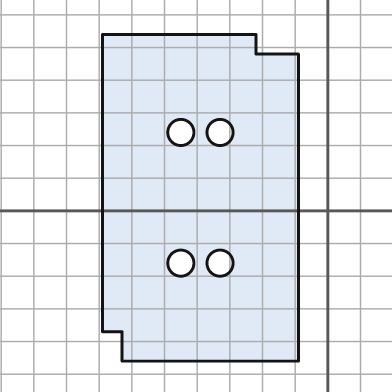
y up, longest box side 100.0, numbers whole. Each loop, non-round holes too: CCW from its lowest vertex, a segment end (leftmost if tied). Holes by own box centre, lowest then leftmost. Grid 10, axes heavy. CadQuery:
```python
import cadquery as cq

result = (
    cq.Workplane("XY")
    .moveTo(-63.0, -46.0)
    .lineTo(-9.0, -46.0)
    .lineTo(-9.0, 48.0)
    .lineTo(-22.0, 48.0)
    .lineTo(-22.0, 54.0)
    .lineTo(-69.0, 54.0)
    .lineTo(-69.0, -37.0)
    .lineTo(-63.0, -37.0)
    .close()
    .moveTo(-45.0, -16.0)
    .circle(4.0)
    .moveTo(-33.0, -16.0)
    .circle(4.0)
    .moveTo(-45.0, 24.0)
    .circle(4.0)
    .moveTo(-33.0, 24.0)
    .circle(4.0)
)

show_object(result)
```